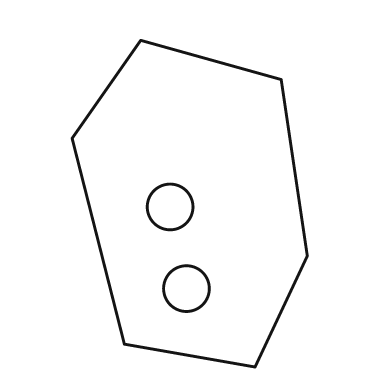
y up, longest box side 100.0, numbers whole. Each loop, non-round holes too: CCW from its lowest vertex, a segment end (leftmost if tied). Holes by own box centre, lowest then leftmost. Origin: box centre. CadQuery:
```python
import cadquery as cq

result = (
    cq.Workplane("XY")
    .moveTo(20.0, -50.0)
    .lineTo(36.0, -16.0)
    .lineTo(28.0, 38.0)
    .lineTo(-15.0, 50.0)
    .lineTo(-36.0, 20.0)
    .lineTo(-20.0, -43.0)
    .close()
    .moveTo(-1.0, -26.0)
    .circle(7.0)
    .moveTo(-6.0, -1.0)
    .circle(7.0)
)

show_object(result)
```